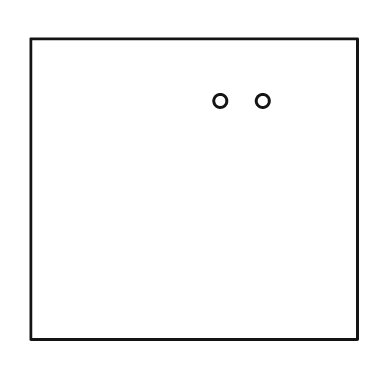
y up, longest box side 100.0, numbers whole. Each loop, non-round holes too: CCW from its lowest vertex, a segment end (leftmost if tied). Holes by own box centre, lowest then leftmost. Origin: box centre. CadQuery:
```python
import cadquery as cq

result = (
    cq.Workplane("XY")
    .moveTo(-50.0, -46.0)
    .lineTo(50.0, -46.0)
    .lineTo(50.0, 46.0)
    .lineTo(-50.0, 46.0)
    .close()
    .moveTo(8.0, 27.0)
    .circle(2.0)
    .moveTo(21.0, 27.0)
    .circle(2.0)
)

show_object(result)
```